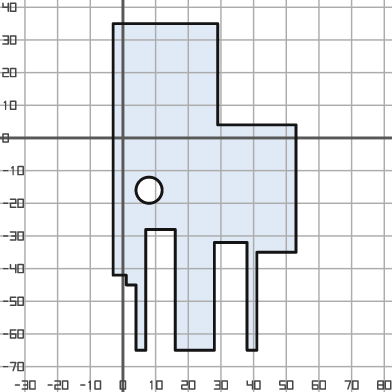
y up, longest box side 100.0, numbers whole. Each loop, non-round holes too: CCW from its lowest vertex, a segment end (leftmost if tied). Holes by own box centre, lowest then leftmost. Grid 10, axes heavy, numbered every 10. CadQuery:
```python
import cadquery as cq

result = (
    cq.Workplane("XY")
    .moveTo(4.0, -65.0)
    .lineTo(7.0, -65.0)
    .lineTo(7.0, -28.0)
    .lineTo(16.0, -28.0)
    .lineTo(16.0, -65.0)
    .lineTo(28.0, -65.0)
    .lineTo(28.0, -32.0)
    .lineTo(38.0, -32.0)
    .lineTo(38.0, -65.0)
    .lineTo(41.0, -65.0)
    .lineTo(41.0, -35.0)
    .lineTo(53.0, -35.0)
    .lineTo(53.0, 4.0)
    .lineTo(29.0, 4.0)
    .lineTo(29.0, 35.0)
    .lineTo(-3.0, 35.0)
    .lineTo(-3.0, -42.0)
    .lineTo(1.0, -42.0)
    .lineTo(1.0, -45.0)
    .lineTo(4.0, -45.0)
    .close()
    .moveTo(8.0, -16.0)
    .circle(4.0)
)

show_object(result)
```